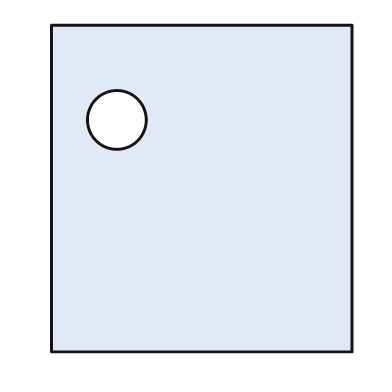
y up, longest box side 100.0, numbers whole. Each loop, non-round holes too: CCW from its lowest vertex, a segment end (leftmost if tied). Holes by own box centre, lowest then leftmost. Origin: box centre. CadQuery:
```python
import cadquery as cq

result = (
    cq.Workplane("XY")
    .moveTo(-46.0, -50.0)
    .lineTo(46.0, -50.0)
    .lineTo(46.0, 50.0)
    .lineTo(-46.0, 50.0)
    .close()
    .moveTo(-26.0, 21.0)
    .circle(9.0)
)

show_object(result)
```